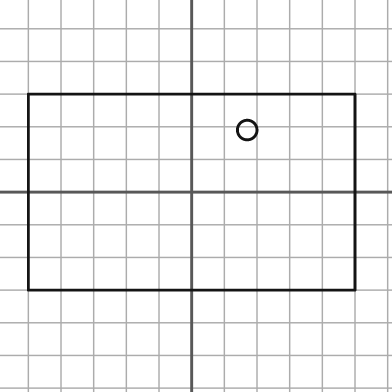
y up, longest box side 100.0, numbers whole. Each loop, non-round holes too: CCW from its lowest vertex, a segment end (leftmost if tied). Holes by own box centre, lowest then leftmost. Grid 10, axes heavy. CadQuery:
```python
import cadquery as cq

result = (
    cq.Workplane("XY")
    .moveTo(-50.0, -30.0)
    .lineTo(50.0, -30.0)
    .lineTo(50.0, 30.0)
    .lineTo(-50.0, 30.0)
    .close()
    .moveTo(17.0, 19.0)
    .circle(3.0)
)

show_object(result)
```